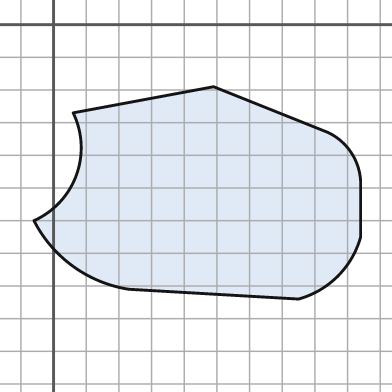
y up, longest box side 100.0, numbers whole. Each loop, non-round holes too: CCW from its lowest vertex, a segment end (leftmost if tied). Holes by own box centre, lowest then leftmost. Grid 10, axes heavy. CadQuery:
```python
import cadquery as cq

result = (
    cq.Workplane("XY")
    .moveTo(75.0, -84.0)
    .threePointArc((87.0, -77.0), (94.0, -65.0))
    .lineTo(94.0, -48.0)
    .threePointArc((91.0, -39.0), (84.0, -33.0))
    .lineTo(49.0, -19.0)
    .lineTo(6.0, -27.0)
    .threePointArc((7.0, -46.0), (-6.0, -60.0))
    .threePointArc((6.0, -74.0), (23.0, -81.0))
    .close()
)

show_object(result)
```